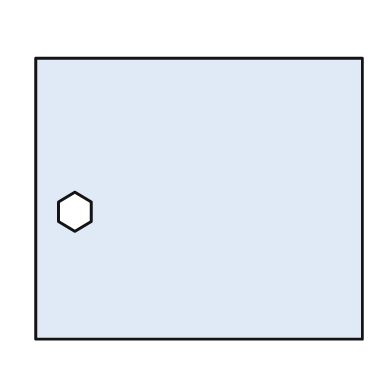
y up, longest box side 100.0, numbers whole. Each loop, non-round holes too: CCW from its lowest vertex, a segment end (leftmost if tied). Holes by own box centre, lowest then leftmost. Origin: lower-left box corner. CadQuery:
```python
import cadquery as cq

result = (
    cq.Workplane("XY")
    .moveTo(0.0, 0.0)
    .lineTo(100.0, 0.0)
    .lineTo(100.0, 86.0)
    .lineTo(0.0, 86.0)
    .close()
    .moveTo(12.0, 33.0)
    .lineTo(17.0, 36.0)
    .lineTo(17.0, 42.0)
    .lineTo(12.0, 45.0)
    .lineTo(7.0, 42.0)
    .lineTo(7.0, 36.0)
    .close()
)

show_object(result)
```